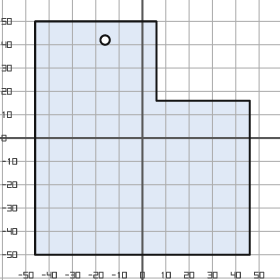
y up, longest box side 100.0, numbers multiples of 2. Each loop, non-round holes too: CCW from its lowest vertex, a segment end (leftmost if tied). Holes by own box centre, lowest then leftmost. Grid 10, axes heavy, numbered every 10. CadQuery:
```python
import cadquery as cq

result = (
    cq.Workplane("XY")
    .moveTo(-46.0, -50.0)
    .lineTo(46.0, -50.0)
    .lineTo(46.0, 16.0)
    .lineTo(6.0, 16.0)
    .lineTo(6.0, 50.0)
    .lineTo(-46.0, 50.0)
    .close()
    .moveTo(-16.0, 42.0)
    .circle(2.0)
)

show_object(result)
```